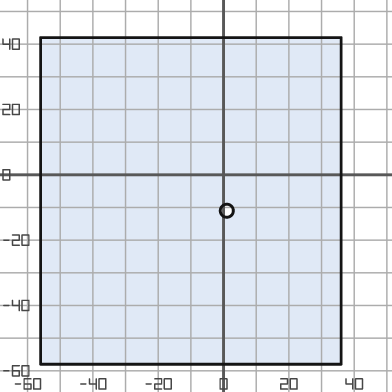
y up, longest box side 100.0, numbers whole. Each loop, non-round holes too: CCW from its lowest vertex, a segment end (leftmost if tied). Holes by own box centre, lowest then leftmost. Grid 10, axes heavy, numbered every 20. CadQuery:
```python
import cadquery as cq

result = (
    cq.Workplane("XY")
    .moveTo(-56.0, -58.0)
    .lineTo(36.0, -58.0)
    .lineTo(36.0, 42.0)
    .lineTo(-56.0, 42.0)
    .close()
    .moveTo(1.0, -11.0)
    .circle(2.0)
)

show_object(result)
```